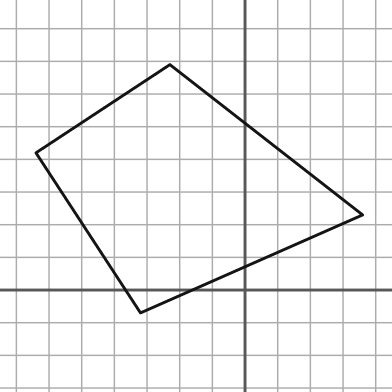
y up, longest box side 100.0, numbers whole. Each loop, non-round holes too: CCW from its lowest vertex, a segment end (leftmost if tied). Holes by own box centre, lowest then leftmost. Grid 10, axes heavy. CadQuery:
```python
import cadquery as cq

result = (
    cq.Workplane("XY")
    .moveTo(-32.0, -7.0)
    .lineTo(36.0, 23.0)
    .lineTo(-23.0, 69.0)
    .lineTo(-64.0, 42.0)
    .close()
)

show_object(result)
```